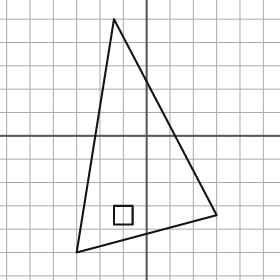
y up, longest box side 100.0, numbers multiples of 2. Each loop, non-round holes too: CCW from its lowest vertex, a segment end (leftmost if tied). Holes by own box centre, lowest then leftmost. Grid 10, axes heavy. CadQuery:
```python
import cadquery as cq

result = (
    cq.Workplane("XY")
    .moveTo(-30.0, -50.0)
    .lineTo(30.0, -34.0)
    .lineTo(-14.0, 50.0)
    .close()
    .moveTo(-14.0, -38.0)
    .lineTo(-6.0, -38.0)
    .lineTo(-6.0, -30.0)
    .lineTo(-14.0, -30.0)
    .close()
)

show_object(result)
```